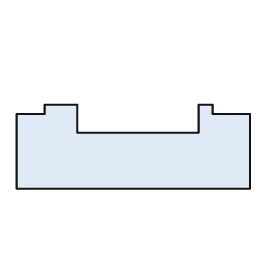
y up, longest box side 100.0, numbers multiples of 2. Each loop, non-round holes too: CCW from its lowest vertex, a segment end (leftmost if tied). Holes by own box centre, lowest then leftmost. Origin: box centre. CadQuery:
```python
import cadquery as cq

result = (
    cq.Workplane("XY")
    .moveTo(-50.0, -18.0)
    .lineTo(50.0, -18.0)
    .lineTo(50.0, 14.0)
    .lineTo(34.0, 14.0)
    .lineTo(34.0, 18.0)
    .lineTo(28.0, 18.0)
    .lineTo(28.0, 6.0)
    .lineTo(-24.0, 6.0)
    .lineTo(-24.0, 18.0)
    .lineTo(-38.0, 18.0)
    .lineTo(-38.0, 14.0)
    .lineTo(-50.0, 14.0)
    .close()
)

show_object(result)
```